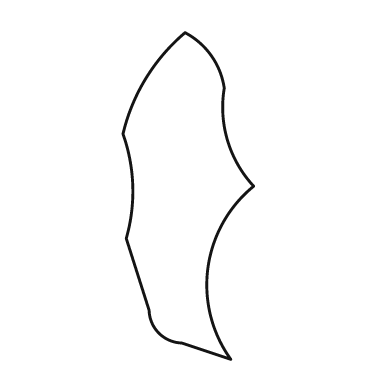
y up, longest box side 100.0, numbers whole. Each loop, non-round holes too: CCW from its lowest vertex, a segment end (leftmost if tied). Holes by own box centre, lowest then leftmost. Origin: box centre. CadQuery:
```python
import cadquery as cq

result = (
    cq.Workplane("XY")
    .moveTo(13.0, -50.0)
    .threePointArc((6.0, -22.0), (20.0, 3.0))
    .threePointArc((12.0, 17.0), (11.0, 33.0))
    .threePointArc((7.0, 43.0), (-1.0, 50.0))
    .threePointArc((-13.0, 36.0), (-20.0, 19.0))
    .threePointArc((-17.0, 3.0), (-19.0, -13.0))
    .lineTo(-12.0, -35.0)
    .threePointArc((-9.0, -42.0), (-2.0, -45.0))
    .close()
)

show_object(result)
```